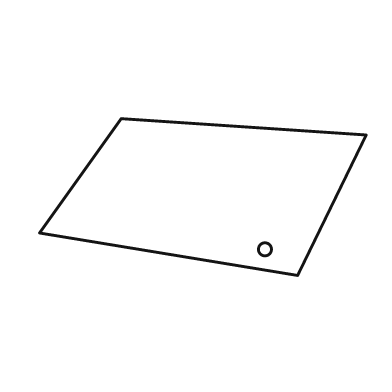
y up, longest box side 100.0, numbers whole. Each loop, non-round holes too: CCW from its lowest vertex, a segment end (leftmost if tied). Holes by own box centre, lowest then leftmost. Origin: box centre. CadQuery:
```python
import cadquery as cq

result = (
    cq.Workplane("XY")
    .moveTo(29.0, -24.0)
    .lineTo(50.0, 19.0)
    .lineTo(-25.0, 24.0)
    .lineTo(-50.0, -11.0)
    .close()
    .moveTo(19.0, -16.0)
    .circle(2.0)
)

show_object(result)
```